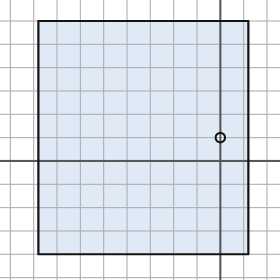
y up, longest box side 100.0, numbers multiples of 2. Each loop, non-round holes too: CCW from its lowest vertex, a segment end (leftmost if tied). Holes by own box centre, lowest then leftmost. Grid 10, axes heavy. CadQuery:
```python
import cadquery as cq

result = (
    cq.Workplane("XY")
    .moveTo(-78.0, -40.0)
    .lineTo(12.0, -40.0)
    .lineTo(12.0, 60.0)
    .lineTo(-78.0, 60.0)
    .close()
    .moveTo(0.0, 10.0)
    .circle(2.0)
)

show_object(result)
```